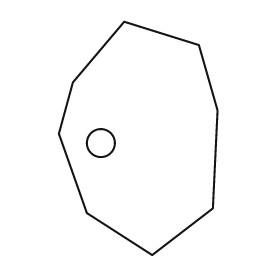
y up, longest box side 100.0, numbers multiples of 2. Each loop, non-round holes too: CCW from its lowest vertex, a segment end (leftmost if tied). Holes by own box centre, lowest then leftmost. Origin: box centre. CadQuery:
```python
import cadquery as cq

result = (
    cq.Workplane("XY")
    .moveTo(6.0, -50.0)
    .lineTo(32.0, -30.0)
    .lineTo(34.0, 12.0)
    .lineTo(26.0, 40.0)
    .lineTo(-6.0, 50.0)
    .lineTo(-28.0, 24.0)
    .lineTo(-34.0, 2.0)
    .lineTo(-22.0, -32.0)
    .close()
    .moveTo(-16.0, -2.0)
    .circle(6.0)
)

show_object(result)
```